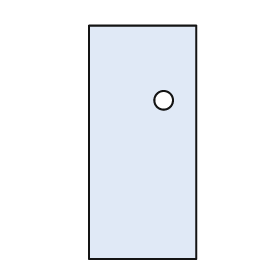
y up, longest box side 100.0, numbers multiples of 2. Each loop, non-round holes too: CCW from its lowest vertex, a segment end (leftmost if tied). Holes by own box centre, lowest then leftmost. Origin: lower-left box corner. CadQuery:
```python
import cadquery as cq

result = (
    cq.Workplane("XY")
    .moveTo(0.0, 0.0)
    .lineTo(46.0, 0.0)
    .lineTo(46.0, 100.0)
    .lineTo(0.0, 100.0)
    .close()
    .moveTo(32.0, 68.0)
    .circle(4.0)
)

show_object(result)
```